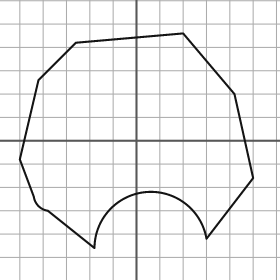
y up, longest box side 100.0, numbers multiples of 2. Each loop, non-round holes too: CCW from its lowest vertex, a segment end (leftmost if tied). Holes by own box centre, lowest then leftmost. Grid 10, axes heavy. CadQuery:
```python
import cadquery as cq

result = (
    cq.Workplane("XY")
    .moveTo(-18.0, -46.0)
    .threePointArc((4.0, -22.0), (30.0, -42.0))
    .lineTo(50.0, -16.0)
    .lineTo(42.0, 20.0)
    .lineTo(20.0, 46.0)
    .lineTo(-26.0, 42.0)
    .lineTo(-42.0, 26.0)
    .lineTo(-50.0, -8.0)
    .lineTo(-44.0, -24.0)
    .threePointArc((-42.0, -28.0), (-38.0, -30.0))
    .close()
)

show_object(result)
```